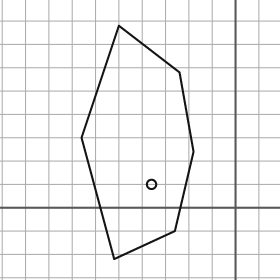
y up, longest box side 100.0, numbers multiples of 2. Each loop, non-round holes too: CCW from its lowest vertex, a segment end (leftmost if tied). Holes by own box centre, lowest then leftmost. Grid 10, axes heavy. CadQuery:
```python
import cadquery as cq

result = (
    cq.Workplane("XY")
    .moveTo(-52.0, -22.0)
    .lineTo(-26.0, -10.0)
    .lineTo(-18.0, 24.0)
    .lineTo(-24.0, 58.0)
    .lineTo(-50.0, 78.0)
    .lineTo(-66.0, 30.0)
    .close()
    .moveTo(-36.0, 10.0)
    .circle(2.0)
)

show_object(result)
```